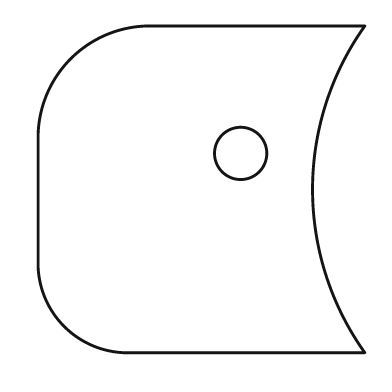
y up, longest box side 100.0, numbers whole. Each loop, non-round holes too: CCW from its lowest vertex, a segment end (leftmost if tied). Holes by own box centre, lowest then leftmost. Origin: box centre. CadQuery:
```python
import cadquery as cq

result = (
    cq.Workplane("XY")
    .moveTo(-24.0, -50.0)
    .lineTo(50.0, -50.0)
    .threePointArc((34.0, 0.0), (50.0, 50.0))
    .lineTo(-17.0, 50.0)
    .threePointArc((-40.0, 40.0), (-50.0, 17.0))
    .lineTo(-50.0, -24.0)
    .threePointArc((-42.0, -42.0), (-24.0, -50.0))
    .close()
    .moveTo(12.0, 11.0)
    .circle(8.0)
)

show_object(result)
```